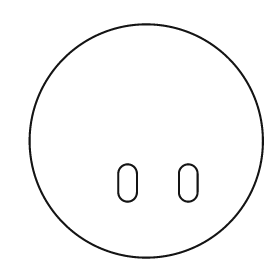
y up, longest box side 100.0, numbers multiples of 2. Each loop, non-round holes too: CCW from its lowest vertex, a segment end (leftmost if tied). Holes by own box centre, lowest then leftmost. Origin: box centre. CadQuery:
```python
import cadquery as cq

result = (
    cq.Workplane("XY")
    .moveTo(0.0, 0.0)
    .circle(50.0)
    .moveTo(-12.0, -22.0)
    .threePointArc((-8.0, -26.0), (-4.0, -22.0))
    .lineTo(-4.0, -14.0)
    .threePointArc((-8.0, -10.0), (-12.0, -14.0))
    .close()
    .moveTo(14.0, -22.0)
    .threePointArc((18.0, -26.0), (22.0, -22.0))
    .lineTo(22.0, -14.0)
    .threePointArc((18.0, -10.0), (14.0, -14.0))
    .close()
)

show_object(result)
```